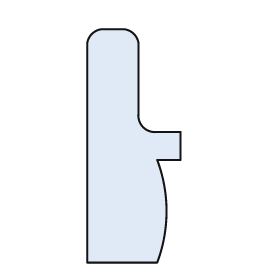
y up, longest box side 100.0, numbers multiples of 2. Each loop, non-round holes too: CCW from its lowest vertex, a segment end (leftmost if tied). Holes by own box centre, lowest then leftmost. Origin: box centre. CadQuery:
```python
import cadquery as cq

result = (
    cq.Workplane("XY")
    .moveTo(-20.0, -50.0)
    .lineTo(10.0, -50.0)
    .threePointArc((14.0, -28.0), (10.0, -6.0))
    .lineTo(20.0, -6.0)
    .lineTo(20.0, 6.0)
    .lineTo(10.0, 6.0)
    .threePointArc((4.0, 8.0), (2.0, 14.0))
    .lineTo(2.0, 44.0)
    .threePointArc((0.0, 48.0), (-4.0, 50.0))
    .lineTo(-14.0, 50.0)
    .threePointArc((-18.0, 48.0), (-20.0, 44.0))
    .close()
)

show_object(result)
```